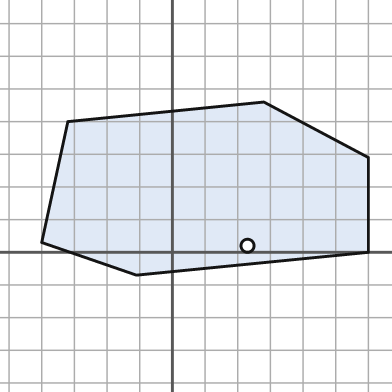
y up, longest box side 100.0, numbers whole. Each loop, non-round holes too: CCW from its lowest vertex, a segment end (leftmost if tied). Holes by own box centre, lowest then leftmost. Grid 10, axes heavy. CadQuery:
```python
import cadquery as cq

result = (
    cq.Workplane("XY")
    .moveTo(-11.0, -7.0)
    .lineTo(60.0, 0.0)
    .lineTo(60.0, 29.0)
    .lineTo(28.0, 46.0)
    .lineTo(-32.0, 40.0)
    .lineTo(-40.0, 3.0)
    .close()
    .moveTo(23.0, 2.0)
    .circle(2.0)
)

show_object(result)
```